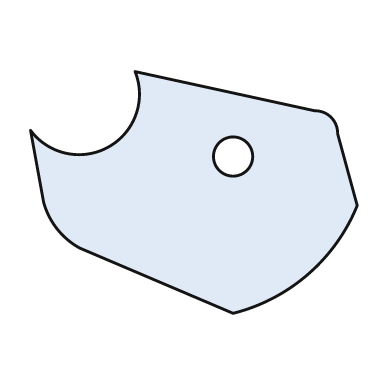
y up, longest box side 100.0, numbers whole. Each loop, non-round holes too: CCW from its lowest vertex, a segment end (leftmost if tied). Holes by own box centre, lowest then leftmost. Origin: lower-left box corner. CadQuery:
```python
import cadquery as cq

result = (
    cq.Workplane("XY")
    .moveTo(62.0, 0.0)
    .threePointArc((85.0, 12.0), (100.0, 33.0))
    .lineTo(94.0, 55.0)
    .threePointArc((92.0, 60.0), (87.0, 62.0))
    .lineTo(32.0, 74.0)
    .threePointArc((24.0, 51.0), (0.0, 56.0))
    .lineTo(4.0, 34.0)
    .threePointArc((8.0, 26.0), (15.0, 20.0))
    .close()
    .moveTo(62.0, 48.0)
    .circle(6.0)
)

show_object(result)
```